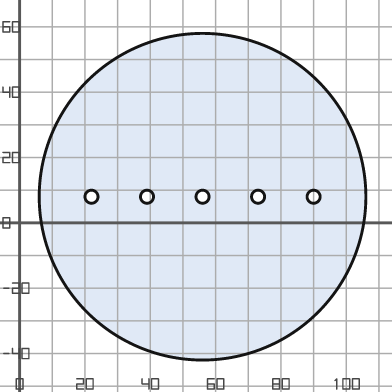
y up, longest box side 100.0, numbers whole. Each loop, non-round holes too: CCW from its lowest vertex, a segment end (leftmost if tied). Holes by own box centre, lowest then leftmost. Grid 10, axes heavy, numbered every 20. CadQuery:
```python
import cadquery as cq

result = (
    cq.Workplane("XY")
    .moveTo(56.0, 8.0)
    .circle(50.0)
    .moveTo(22.0, 8.0)
    .circle(2.0)
    .moveTo(39.0, 8.0)
    .circle(2.0)
    .moveTo(56.0, 8.0)
    .circle(2.0)
    .moveTo(73.0, 8.0)
    .circle(2.0)
    .moveTo(90.0, 8.0)
    .circle(2.0)
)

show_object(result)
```